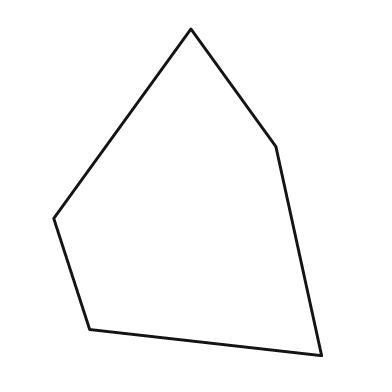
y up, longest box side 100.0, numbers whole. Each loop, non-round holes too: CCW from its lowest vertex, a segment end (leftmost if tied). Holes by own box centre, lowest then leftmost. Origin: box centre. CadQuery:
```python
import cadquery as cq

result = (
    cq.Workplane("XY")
    .moveTo(41.0, -50.0)
    .lineTo(27.0, 14.0)
    .lineTo(1.0, 50.0)
    .lineTo(-41.0, -8.0)
    .lineTo(-30.0, -42.0)
    .close()
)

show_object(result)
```